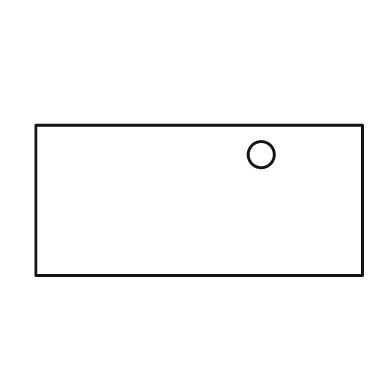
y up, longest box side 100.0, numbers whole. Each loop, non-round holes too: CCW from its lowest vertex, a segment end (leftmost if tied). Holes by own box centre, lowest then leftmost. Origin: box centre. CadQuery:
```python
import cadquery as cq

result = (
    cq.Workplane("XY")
    .moveTo(-50.0, -23.0)
    .lineTo(50.0, -23.0)
    .lineTo(50.0, 23.0)
    .lineTo(-50.0, 23.0)
    .close()
    .moveTo(19.0, 14.0)
    .circle(4.0)
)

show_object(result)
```